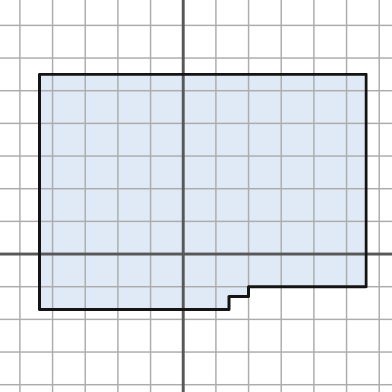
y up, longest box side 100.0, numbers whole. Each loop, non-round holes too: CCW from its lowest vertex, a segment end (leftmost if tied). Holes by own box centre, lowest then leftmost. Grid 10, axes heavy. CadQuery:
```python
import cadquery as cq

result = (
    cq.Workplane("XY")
    .moveTo(-44.0, -17.0)
    .lineTo(14.0, -17.0)
    .lineTo(14.0, -13.0)
    .lineTo(20.0, -13.0)
    .lineTo(20.0, -10.0)
    .lineTo(56.0, -10.0)
    .lineTo(56.0, 55.0)
    .lineTo(-44.0, 55.0)
    .close()
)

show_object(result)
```